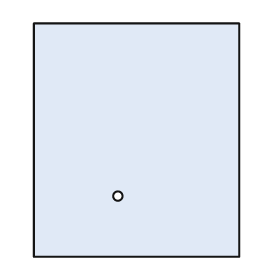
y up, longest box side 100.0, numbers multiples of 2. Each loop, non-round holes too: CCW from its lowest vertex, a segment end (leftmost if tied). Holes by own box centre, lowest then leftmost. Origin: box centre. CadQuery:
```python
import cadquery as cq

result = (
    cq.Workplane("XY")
    .moveTo(-44.0, -50.0)
    .lineTo(44.0, -50.0)
    .lineTo(44.0, 50.0)
    .lineTo(-44.0, 50.0)
    .close()
    .moveTo(-8.0, -24.0)
    .circle(2.0)
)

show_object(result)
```